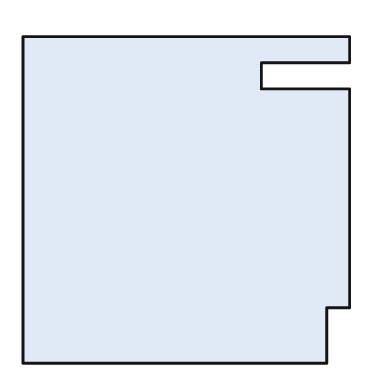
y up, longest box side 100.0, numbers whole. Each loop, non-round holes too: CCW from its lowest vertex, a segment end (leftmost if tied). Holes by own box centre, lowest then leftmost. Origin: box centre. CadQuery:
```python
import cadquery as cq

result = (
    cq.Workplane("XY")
    .moveTo(-50.0, -50.0)
    .lineTo(43.0, -50.0)
    .lineTo(43.0, -33.0)
    .lineTo(50.0, -33.0)
    .lineTo(50.0, 34.0)
    .lineTo(23.0, 34.0)
    .lineTo(23.0, 42.0)
    .lineTo(50.0, 42.0)
    .lineTo(50.0, 50.0)
    .lineTo(-50.0, 50.0)
    .close()
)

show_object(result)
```